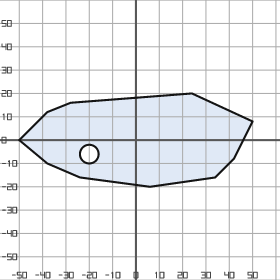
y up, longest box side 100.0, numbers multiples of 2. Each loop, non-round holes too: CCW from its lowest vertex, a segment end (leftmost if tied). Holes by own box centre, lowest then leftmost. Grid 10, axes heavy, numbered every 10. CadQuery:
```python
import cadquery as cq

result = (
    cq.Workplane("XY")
    .moveTo(6.0, -20.0)
    .lineTo(34.0, -16.0)
    .lineTo(42.0, -8.0)
    .lineTo(50.0, 8.0)
    .lineTo(24.0, 20.0)
    .lineTo(-28.0, 16.0)
    .lineTo(-38.0, 12.0)
    .lineTo(-50.0, 0.0)
    .lineTo(-38.0, -10.0)
    .lineTo(-24.0, -16.0)
    .close()
    .moveTo(-20.0, -6.0)
    .circle(4.0)
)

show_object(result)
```